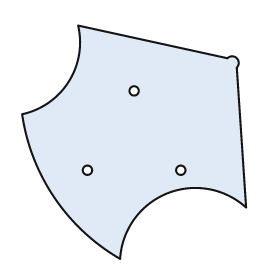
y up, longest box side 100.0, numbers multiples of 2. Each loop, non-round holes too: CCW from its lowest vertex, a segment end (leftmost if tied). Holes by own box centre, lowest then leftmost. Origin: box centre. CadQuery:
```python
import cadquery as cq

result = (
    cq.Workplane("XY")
    .moveTo(-6.0, -50.0)
    .threePointArc((14.0, -22.0), (48.0, -28.0))
    .lineTo(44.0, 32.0)
    .threePointArc((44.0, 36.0), (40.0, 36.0))
    .lineTo(-24.0, 50.0)
    .threePointArc((-28.0, 26.0), (-48.0, 12.0))
    .threePointArc((-34.0, -24.0), (-6.0, -50.0))
    .close()
    .moveTo(-20.0, -12.0)
    .circle(2.0)
    .moveTo(20.0, -12.0)
    .circle(2.0)
    .moveTo(0.0, 22.0)
    .circle(2.0)
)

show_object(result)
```